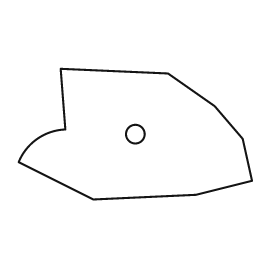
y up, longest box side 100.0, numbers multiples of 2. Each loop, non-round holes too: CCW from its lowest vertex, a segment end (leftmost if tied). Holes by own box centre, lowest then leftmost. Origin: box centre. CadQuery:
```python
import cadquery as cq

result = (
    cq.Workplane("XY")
    .moveTo(-18.0, -28.0)
    .lineTo(26.0, -26.0)
    .lineTo(50.0, -20.0)
    .lineTo(46.0, -2.0)
    .lineTo(34.0, 12.0)
    .lineTo(14.0, 26.0)
    .lineTo(-32.0, 28.0)
    .lineTo(-30.0, 2.0)
    .threePointArc((-42.0, -2.0), (-50.0, -12.0))
    .close()
    .moveTo(0.0, 0.0)
    .circle(4.0)
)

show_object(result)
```